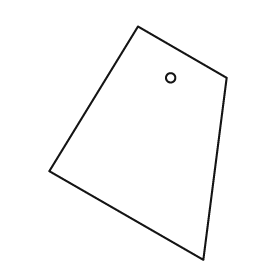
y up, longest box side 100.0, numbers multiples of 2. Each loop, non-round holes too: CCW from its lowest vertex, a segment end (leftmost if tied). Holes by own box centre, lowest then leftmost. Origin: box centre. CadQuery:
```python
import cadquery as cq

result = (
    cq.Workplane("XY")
    .moveTo(28.0, -50.0)
    .lineTo(38.0, 28.0)
    .lineTo(0.0, 50.0)
    .lineTo(-38.0, -12.0)
    .close()
    .moveTo(14.0, 28.0)
    .circle(2.0)
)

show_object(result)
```